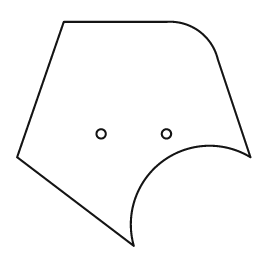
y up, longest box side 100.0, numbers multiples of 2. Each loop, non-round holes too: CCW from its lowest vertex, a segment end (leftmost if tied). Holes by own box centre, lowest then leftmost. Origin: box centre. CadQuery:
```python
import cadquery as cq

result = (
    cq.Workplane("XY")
    .moveTo(0.0, -48.0)
    .threePointArc((12.0, -12.0), (50.0, -10.0))
    .lineTo(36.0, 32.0)
    .threePointArc((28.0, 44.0), (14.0, 48.0))
    .lineTo(-30.0, 48.0)
    .lineTo(-50.0, -10.0)
    .close()
    .moveTo(-14.0, 0.0)
    .circle(2.0)
    .moveTo(14.0, 0.0)
    .circle(2.0)
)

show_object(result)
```